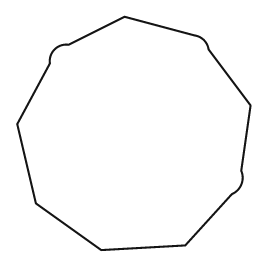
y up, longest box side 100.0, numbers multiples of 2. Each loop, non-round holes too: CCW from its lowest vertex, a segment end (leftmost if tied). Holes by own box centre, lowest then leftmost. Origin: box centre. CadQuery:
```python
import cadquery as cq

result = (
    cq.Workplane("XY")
    .moveTo(-14.0, -50.0)
    .lineTo(22.0, -48.0)
    .lineTo(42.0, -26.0)
    .threePointArc((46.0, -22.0), (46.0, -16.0))
    .lineTo(50.0, 12.0)
    .lineTo(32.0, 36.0)
    .threePointArc((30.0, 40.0), (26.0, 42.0))
    .lineTo(-4.0, 50.0)
    .lineTo(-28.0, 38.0)
    .threePointArc((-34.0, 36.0), (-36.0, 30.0))
    .lineTo(-50.0, 4.0)
    .lineTo(-42.0, -30.0)
    .close()
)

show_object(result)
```